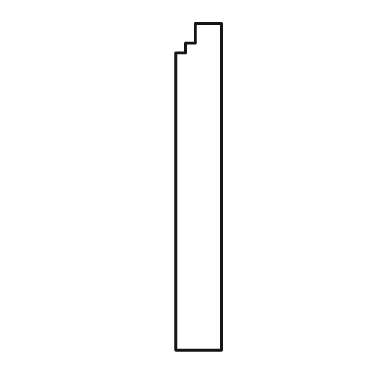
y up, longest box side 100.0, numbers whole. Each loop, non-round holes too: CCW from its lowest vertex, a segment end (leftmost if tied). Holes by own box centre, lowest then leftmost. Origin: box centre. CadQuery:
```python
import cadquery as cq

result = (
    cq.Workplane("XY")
    .moveTo(-7.0, -50.0)
    .lineTo(7.0, -50.0)
    .lineTo(7.0, 50.0)
    .lineTo(-1.0, 50.0)
    .lineTo(-1.0, 44.0)
    .lineTo(-4.0, 44.0)
    .lineTo(-4.0, 41.0)
    .lineTo(-7.0, 41.0)
    .close()
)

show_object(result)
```